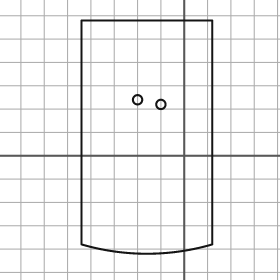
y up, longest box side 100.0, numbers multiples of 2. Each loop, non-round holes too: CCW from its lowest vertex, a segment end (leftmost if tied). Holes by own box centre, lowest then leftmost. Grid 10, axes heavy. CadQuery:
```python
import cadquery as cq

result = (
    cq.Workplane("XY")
    .moveTo(-44.0, -38.0)
    .threePointArc((-16.0, -42.0), (12.0, -38.0))
    .lineTo(12.0, 58.0)
    .lineTo(-44.0, 58.0)
    .close()
    .moveTo(-10.0, 22.0)
    .circle(2.0)
    .moveTo(-20.0, 24.0)
    .circle(2.0)
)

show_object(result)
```